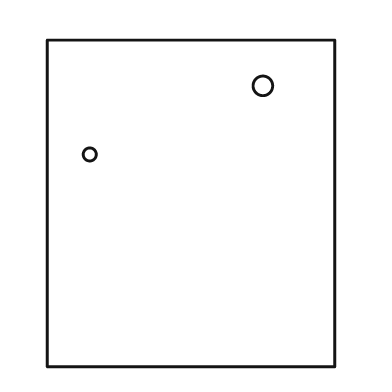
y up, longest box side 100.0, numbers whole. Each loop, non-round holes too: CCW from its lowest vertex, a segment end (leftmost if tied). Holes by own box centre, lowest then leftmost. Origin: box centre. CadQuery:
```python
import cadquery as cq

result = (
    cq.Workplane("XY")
    .moveTo(-44.0, -50.0)
    .lineTo(44.0, -50.0)
    .lineTo(44.0, 50.0)
    .lineTo(-44.0, 50.0)
    .close()
    .moveTo(-31.0, 15.0)
    .circle(2.0)
    .moveTo(22.0, 36.0)
    .circle(3.0)
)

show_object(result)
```